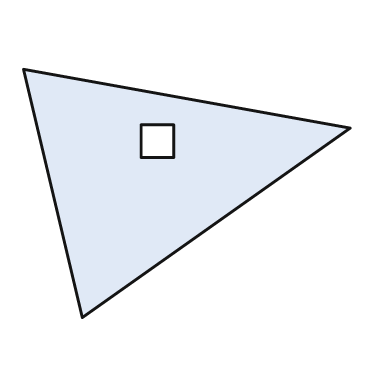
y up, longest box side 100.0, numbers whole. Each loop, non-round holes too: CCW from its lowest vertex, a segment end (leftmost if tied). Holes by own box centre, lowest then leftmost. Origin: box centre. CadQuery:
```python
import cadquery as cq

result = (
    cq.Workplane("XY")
    .moveTo(-32.0, -38.0)
    .lineTo(50.0, 20.0)
    .lineTo(-50.0, 38.0)
    .close()
    .moveTo(-14.0, 11.0)
    .lineTo(-4.0, 11.0)
    .lineTo(-4.0, 21.0)
    .lineTo(-14.0, 21.0)
    .close()
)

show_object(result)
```